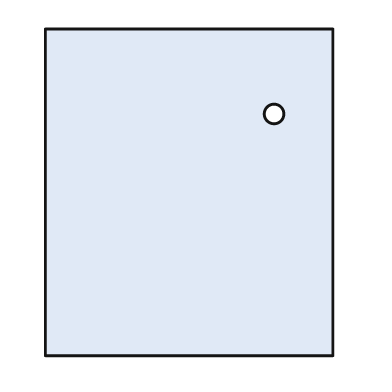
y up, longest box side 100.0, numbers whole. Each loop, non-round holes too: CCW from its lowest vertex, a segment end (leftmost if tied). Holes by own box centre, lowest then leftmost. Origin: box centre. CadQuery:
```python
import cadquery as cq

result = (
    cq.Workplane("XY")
    .moveTo(-44.0, -50.0)
    .lineTo(44.0, -50.0)
    .lineTo(44.0, 50.0)
    .lineTo(-44.0, 50.0)
    .close()
    .moveTo(26.0, 24.0)
    .circle(3.0)
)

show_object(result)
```